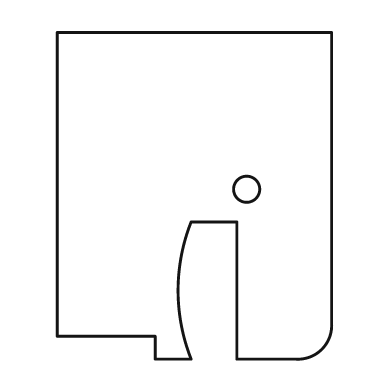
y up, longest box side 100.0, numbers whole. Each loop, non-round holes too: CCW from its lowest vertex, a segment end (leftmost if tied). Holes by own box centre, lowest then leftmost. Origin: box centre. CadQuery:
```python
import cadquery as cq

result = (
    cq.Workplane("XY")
    .moveTo(-12.0, -50.0)
    .lineTo(-1.0, -50.0)
    .threePointArc((-5.0, -29.0), (-1.0, -8.0))
    .lineTo(13.0, -8.0)
    .lineTo(13.0, -50.0)
    .lineTo(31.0, -50.0)
    .threePointArc((39.0, -47.0), (42.0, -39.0))
    .lineTo(42.0, 50.0)
    .lineTo(-42.0, 50.0)
    .lineTo(-42.0, -43.0)
    .lineTo(-12.0, -43.0)
    .close()
    .moveTo(16.0, 2.0)
    .circle(4.0)
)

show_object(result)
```